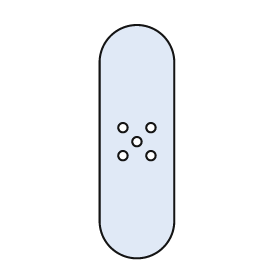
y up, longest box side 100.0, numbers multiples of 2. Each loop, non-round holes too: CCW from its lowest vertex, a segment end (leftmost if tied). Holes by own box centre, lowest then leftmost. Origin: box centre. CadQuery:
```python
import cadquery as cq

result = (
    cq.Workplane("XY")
    .moveTo(-16.0, -34.0)
    .threePointArc((0.0, -50.0), (16.0, -34.0))
    .lineTo(16.0, 34.0)
    .threePointArc((0.0, 50.0), (-16.0, 34.0))
    .close()
    .moveTo(-6.0, -6.0)
    .circle(2.0)
    .moveTo(6.0, -6.0)
    .circle(2.0)
    .moveTo(0.0, 0.0)
    .circle(2.0)
    .moveTo(-6.0, 6.0)
    .circle(2.0)
    .moveTo(6.0, 6.0)
    .circle(2.0)
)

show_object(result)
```